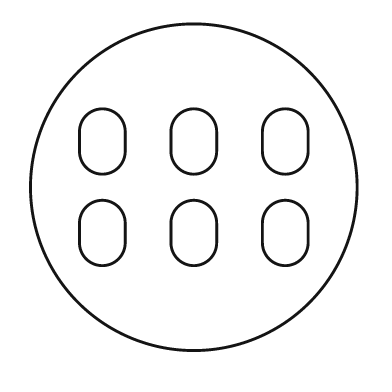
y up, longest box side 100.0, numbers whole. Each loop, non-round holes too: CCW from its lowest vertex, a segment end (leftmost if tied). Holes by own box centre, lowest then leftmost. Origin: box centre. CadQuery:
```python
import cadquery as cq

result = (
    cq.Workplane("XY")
    .moveTo(0.0, 0.0)
    .circle(50.0)
    .moveTo(-35.0, -17.0)
    .threePointArc((-28.0, -24.0), (-21.0, -17.0))
    .lineTo(-21.0, -11.0)
    .threePointArc((-28.0, -4.0), (-35.0, -11.0))
    .close()
    .moveTo(-7.0, -17.0)
    .threePointArc((0.0, -24.0), (7.0, -17.0))
    .lineTo(7.0, -11.0)
    .threePointArc((0.0, -4.0), (-7.0, -11.0))
    .close()
    .moveTo(21.0, -17.0)
    .threePointArc((28.0, -24.0), (35.0, -17.0))
    .lineTo(35.0, -11.0)
    .threePointArc((28.0, -4.0), (21.0, -11.0))
    .close()
    .moveTo(-35.0, 11.0)
    .threePointArc((-28.0, 4.0), (-21.0, 11.0))
    .lineTo(-21.0, 17.0)
    .threePointArc((-28.0, 24.0), (-35.0, 17.0))
    .close()
    .moveTo(-7.0, 11.0)
    .threePointArc((0.0, 4.0), (7.0, 11.0))
    .lineTo(7.0, 17.0)
    .threePointArc((0.0, 24.0), (-7.0, 17.0))
    .close()
    .moveTo(21.0, 11.0)
    .threePointArc((28.0, 4.0), (35.0, 11.0))
    .lineTo(35.0, 17.0)
    .threePointArc((28.0, 24.0), (21.0, 17.0))
    .close()
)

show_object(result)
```